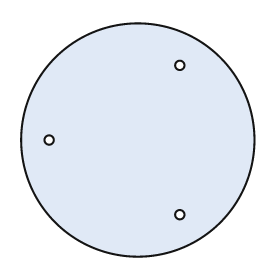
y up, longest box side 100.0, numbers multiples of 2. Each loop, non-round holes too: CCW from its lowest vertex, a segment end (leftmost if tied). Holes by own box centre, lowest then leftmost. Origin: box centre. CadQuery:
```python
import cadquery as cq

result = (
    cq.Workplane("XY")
    .moveTo(0.0, 0.0)
    .circle(50.0)
    .moveTo(18.0, -32.0)
    .circle(2.0)
    .moveTo(-38.0, 0.0)
    .circle(2.0)
    .moveTo(18.0, 32.0)
    .circle(2.0)
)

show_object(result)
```